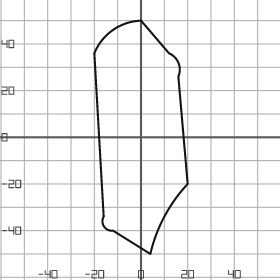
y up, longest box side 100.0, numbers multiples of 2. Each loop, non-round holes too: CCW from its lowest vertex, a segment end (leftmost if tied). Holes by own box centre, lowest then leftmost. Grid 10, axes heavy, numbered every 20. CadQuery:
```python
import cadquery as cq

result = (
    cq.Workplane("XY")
    .moveTo(4.0, -50.0)
    .threePointArc((10.0, -34.0), (20.0, -20.0))
    .lineTo(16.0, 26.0)
    .threePointArc((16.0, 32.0), (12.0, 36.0))
    .lineTo(0.0, 50.0)
    .threePointArc((-12.0, 46.0), (-20.0, 36.0))
    .lineTo(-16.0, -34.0)
    .threePointArc((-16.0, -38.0), (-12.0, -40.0))
    .close()
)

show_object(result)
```